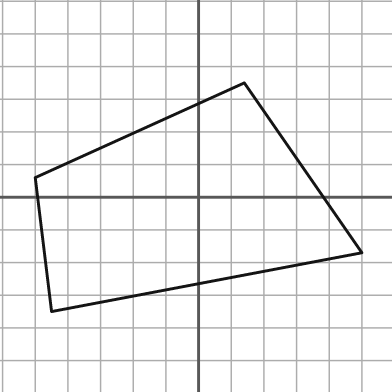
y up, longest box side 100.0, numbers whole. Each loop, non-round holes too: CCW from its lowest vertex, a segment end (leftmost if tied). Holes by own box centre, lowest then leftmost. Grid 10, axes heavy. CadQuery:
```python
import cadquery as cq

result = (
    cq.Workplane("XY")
    .moveTo(-45.0, -35.0)
    .lineTo(50.0, -17.0)
    .lineTo(14.0, 35.0)
    .lineTo(-50.0, 6.0)
    .close()
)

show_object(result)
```